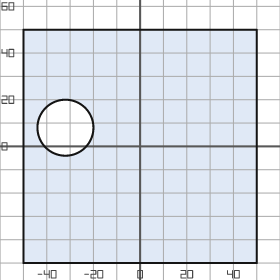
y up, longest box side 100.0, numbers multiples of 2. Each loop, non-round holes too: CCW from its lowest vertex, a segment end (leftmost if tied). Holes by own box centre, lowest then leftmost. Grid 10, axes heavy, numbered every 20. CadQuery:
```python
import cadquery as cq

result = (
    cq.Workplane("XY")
    .moveTo(-50.0, -50.0)
    .lineTo(50.0, -50.0)
    .lineTo(50.0, 50.0)
    .lineTo(-50.0, 50.0)
    .close()
    .moveTo(-32.0, 8.0)
    .circle(12.0)
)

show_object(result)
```